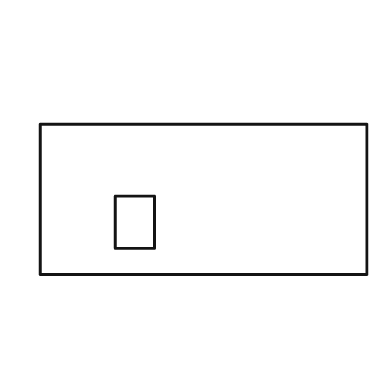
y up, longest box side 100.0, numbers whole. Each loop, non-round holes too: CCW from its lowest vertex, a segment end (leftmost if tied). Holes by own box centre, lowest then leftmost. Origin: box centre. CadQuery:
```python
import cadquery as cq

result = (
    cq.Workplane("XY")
    .moveTo(-50.0, -23.0)
    .lineTo(50.0, -23.0)
    .lineTo(50.0, 23.0)
    .lineTo(-50.0, 23.0)
    .close()
    .moveTo(-27.0, -15.0)
    .lineTo(-15.0, -15.0)
    .lineTo(-15.0, 1.0)
    .lineTo(-27.0, 1.0)
    .close()
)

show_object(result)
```